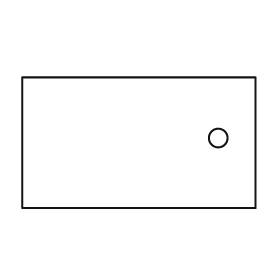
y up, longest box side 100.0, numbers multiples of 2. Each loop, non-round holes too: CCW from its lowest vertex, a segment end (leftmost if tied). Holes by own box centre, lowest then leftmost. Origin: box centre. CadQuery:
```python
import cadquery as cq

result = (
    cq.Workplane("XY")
    .moveTo(-50.0, -28.0)
    .lineTo(50.0, -28.0)
    .lineTo(50.0, 28.0)
    .lineTo(-50.0, 28.0)
    .close()
    .moveTo(34.0, 2.0)
    .circle(4.0)
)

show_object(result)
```